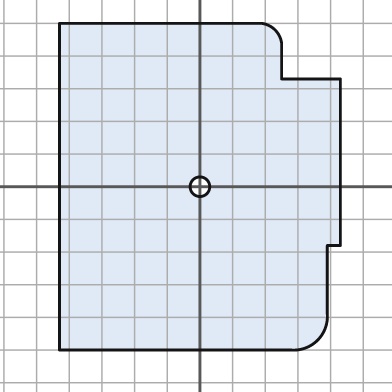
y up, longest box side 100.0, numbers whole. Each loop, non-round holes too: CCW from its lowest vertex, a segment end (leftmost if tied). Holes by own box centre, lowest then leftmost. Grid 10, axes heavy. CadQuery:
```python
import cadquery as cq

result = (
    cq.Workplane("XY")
    .moveTo(-43.0, -50.0)
    .lineTo(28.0, -50.0)
    .threePointArc((36.0, -47.0), (39.0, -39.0))
    .lineTo(39.0, -18.0)
    .lineTo(43.0, -18.0)
    .lineTo(43.0, 33.0)
    .lineTo(25.0, 33.0)
    .lineTo(25.0, 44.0)
    .threePointArc((23.0, 48.0), (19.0, 50.0))
    .lineTo(-43.0, 50.0)
    .close()
    .moveTo(0.0, 0.0)
    .circle(3.0)
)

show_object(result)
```